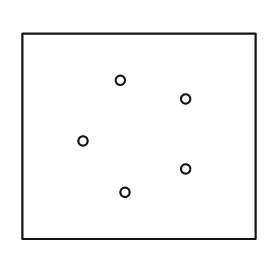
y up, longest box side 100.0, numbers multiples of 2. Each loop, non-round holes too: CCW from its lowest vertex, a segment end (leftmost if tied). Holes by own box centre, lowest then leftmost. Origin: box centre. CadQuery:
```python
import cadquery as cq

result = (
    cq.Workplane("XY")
    .moveTo(-50.0, -44.0)
    .lineTo(50.0, -44.0)
    .lineTo(50.0, 44.0)
    .lineTo(-50.0, 44.0)
    .close()
    .moveTo(-6.0, -24.0)
    .circle(2.0)
    .moveTo(20.0, -14.0)
    .circle(2.0)
    .moveTo(-24.0, -2.0)
    .circle(2.0)
    .moveTo(20.0, 16.0)
    .circle(2.0)
    .moveTo(-8.0, 24.0)
    .circle(2.0)
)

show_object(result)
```